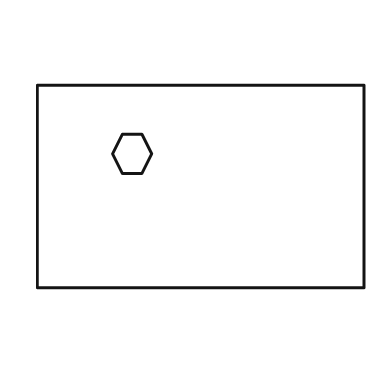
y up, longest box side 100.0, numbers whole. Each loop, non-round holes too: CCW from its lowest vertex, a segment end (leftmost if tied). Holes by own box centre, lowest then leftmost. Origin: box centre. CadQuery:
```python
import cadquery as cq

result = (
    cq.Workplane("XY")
    .moveTo(-50.0, -31.0)
    .lineTo(50.0, -31.0)
    .lineTo(50.0, 31.0)
    .lineTo(-50.0, 31.0)
    .close()
    .moveTo(-24.0, 4.0)
    .lineTo(-18.0, 4.0)
    .lineTo(-15.0, 10.0)
    .lineTo(-18.0, 16.0)
    .lineTo(-24.0, 16.0)
    .lineTo(-27.0, 10.0)
    .close()
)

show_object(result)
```